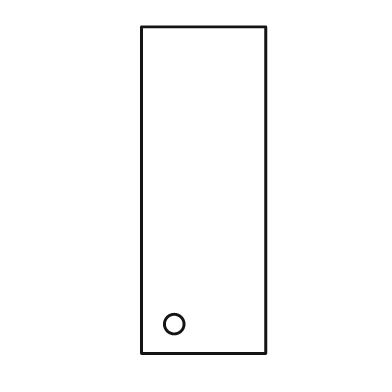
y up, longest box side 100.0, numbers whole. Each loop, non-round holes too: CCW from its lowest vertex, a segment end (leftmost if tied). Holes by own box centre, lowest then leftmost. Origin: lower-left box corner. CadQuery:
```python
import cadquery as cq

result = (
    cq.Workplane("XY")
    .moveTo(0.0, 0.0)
    .lineTo(38.0, 0.0)
    .lineTo(38.0, 100.0)
    .lineTo(0.0, 100.0)
    .close()
    .moveTo(10.0, 9.0)
    .circle(3.0)
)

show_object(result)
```